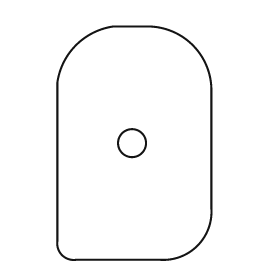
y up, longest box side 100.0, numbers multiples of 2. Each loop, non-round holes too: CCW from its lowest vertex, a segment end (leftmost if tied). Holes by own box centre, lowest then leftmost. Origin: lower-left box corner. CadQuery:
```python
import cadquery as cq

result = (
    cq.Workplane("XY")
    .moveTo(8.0, 0.0)
    .lineTo(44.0, 0.0)
    .threePointArc((60.0, 6.0), (66.0, 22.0))
    .lineTo(66.0, 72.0)
    .threePointArc((58.0, 92.0), (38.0, 100.0))
    .lineTo(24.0, 100.0)
    .threePointArc((8.0, 92.0), (0.0, 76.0))
    .lineTo(0.0, 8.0)
    .threePointArc((2.0, 2.0), (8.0, 0.0))
    .close()
    .moveTo(32.0, 50.0)
    .circle(6.0)
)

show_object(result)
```